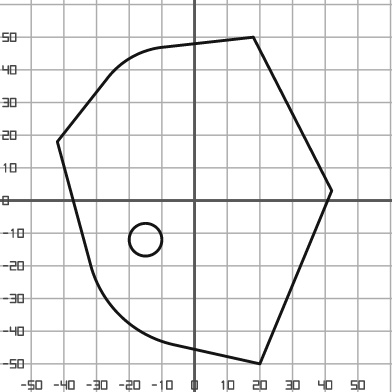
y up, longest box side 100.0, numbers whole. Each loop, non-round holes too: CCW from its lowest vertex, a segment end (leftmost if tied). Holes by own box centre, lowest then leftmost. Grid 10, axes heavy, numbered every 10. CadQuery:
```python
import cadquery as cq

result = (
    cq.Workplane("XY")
    .moveTo(20.0, -50.0)
    .lineTo(42.0, 3.0)
    .lineTo(18.0, 50.0)
    .lineTo(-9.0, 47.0)
    .threePointArc((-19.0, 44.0), (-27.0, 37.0))
    .lineTo(-42.0, 18.0)
    .lineTo(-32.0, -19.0)
    .threePointArc((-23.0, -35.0), (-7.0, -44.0))
    .close()
    .moveTo(-15.0, -12.0)
    .circle(5.0)
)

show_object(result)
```